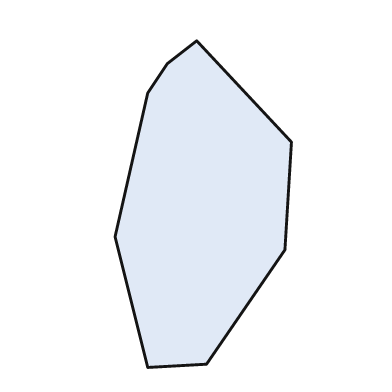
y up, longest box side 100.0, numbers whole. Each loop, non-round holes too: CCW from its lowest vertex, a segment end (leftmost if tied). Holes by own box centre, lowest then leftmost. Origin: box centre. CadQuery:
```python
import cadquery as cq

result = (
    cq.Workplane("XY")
    .moveTo(-17.0, -50.0)
    .lineTo(1.0, -49.0)
    .lineTo(25.0, -14.0)
    .lineTo(27.0, 19.0)
    .lineTo(-2.0, 50.0)
    .lineTo(-11.0, 43.0)
    .lineTo(-17.0, 34.0)
    .lineTo(-27.0, -10.0)
    .close()
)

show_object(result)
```